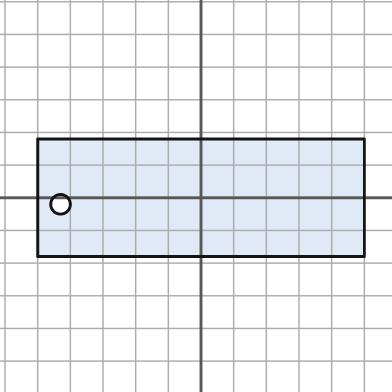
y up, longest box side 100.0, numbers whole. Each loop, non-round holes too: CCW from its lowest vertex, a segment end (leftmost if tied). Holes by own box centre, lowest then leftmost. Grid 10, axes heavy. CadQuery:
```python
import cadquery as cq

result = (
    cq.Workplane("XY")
    .moveTo(-50.0, -18.0)
    .lineTo(50.0, -18.0)
    .lineTo(50.0, 18.0)
    .lineTo(-50.0, 18.0)
    .close()
    .moveTo(-43.0, -2.0)
    .circle(3.0)
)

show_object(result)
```